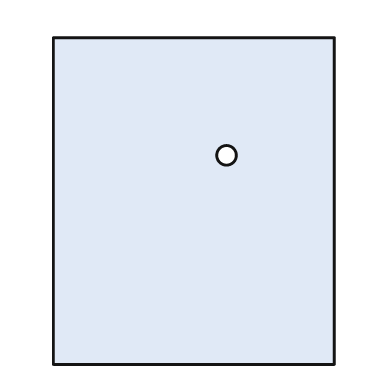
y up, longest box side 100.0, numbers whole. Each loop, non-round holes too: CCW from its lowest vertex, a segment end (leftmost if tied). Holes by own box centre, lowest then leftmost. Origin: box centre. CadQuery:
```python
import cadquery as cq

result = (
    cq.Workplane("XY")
    .moveTo(-43.0, -50.0)
    .lineTo(43.0, -50.0)
    .lineTo(43.0, 50.0)
    .lineTo(-43.0, 50.0)
    .close()
    .moveTo(10.0, 14.0)
    .circle(3.0)
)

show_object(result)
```